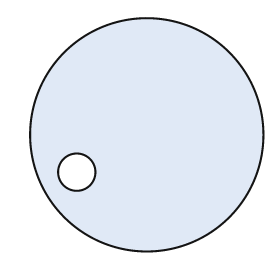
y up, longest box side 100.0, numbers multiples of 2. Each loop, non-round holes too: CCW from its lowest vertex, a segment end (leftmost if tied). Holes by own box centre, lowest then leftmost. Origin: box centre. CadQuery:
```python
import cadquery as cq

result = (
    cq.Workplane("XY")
    .moveTo(0.0, 0.0)
    .circle(50.0)
    .moveTo(-30.0, -16.0)
    .circle(8.0)
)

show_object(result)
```